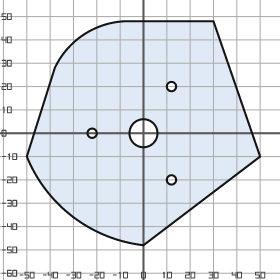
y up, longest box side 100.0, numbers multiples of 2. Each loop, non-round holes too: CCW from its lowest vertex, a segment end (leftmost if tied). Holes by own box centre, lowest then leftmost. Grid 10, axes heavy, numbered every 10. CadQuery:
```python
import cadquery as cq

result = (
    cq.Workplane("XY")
    .moveTo(0.0, -48.0)
    .lineTo(50.0, -10.0)
    .lineTo(30.0, 48.0)
    .lineTo(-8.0, 48.0)
    .threePointArc((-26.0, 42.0), (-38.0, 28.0))
    .lineTo(-50.0, -10.0)
    .threePointArc((-30.0, -36.0), (0.0, -48.0))
    .close()
    .moveTo(12.0, -20.0)
    .circle(2.0)
    .moveTo(-22.0, 0.0)
    .circle(2.0)
    .moveTo(0.0, 0.0)
    .circle(6.0)
    .moveTo(12.0, 20.0)
    .circle(2.0)
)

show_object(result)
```